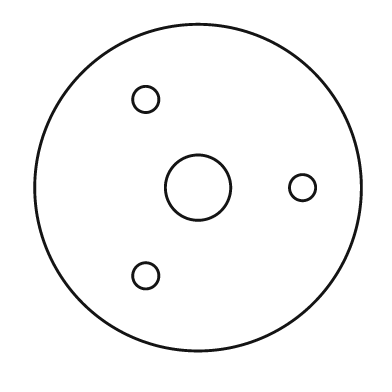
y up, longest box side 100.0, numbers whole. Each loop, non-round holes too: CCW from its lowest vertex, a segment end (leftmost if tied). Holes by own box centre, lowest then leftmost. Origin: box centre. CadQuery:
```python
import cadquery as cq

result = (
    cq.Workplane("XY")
    .moveTo(0.0, 0.0)
    .circle(50.0)
    .moveTo(-16.0, -27.0)
    .circle(4.0)
    .moveTo(0.0, 0.0)
    .circle(10.0)
    .moveTo(32.0, 0.0)
    .circle(4.0)
    .moveTo(-16.0, 27.0)
    .circle(4.0)
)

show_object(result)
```